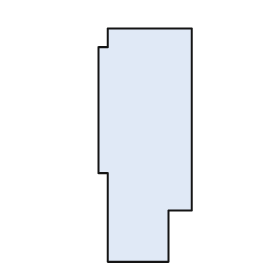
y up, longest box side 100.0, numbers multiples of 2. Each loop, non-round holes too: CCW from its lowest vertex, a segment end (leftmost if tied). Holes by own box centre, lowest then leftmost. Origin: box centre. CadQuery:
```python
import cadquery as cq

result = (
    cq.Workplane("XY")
    .moveTo(-16.0, -50.0)
    .lineTo(10.0, -50.0)
    .lineTo(10.0, -28.0)
    .lineTo(20.0, -28.0)
    .lineTo(20.0, 50.0)
    .lineTo(-16.0, 50.0)
    .lineTo(-16.0, 42.0)
    .lineTo(-20.0, 42.0)
    .lineTo(-20.0, -12.0)
    .lineTo(-16.0, -12.0)
    .close()
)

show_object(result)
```